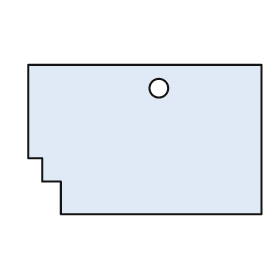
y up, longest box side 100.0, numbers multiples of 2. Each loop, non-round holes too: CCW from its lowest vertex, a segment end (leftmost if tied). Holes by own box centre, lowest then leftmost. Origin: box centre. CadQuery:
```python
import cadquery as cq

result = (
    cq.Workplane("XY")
    .moveTo(-36.0, -32.0)
    .lineTo(50.0, -32.0)
    .lineTo(50.0, 32.0)
    .lineTo(-50.0, 32.0)
    .lineTo(-50.0, -8.0)
    .lineTo(-44.0, -8.0)
    .lineTo(-44.0, -18.0)
    .lineTo(-36.0, -18.0)
    .close()
    .moveTo(6.0, 22.0)
    .circle(4.0)
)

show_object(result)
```